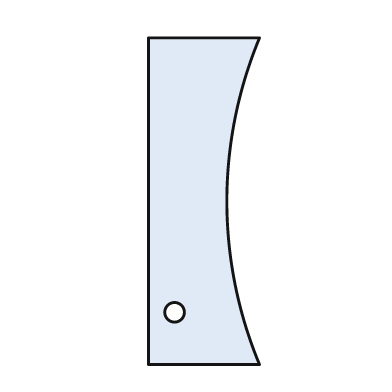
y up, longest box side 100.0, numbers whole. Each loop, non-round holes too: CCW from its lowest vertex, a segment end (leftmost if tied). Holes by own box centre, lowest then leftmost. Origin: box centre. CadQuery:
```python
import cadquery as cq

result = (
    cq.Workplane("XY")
    .moveTo(-17.0, -50.0)
    .lineTo(17.0, -50.0)
    .threePointArc((7.0, 0.0), (17.0, 50.0))
    .lineTo(-17.0, 50.0)
    .close()
    .moveTo(-9.0, -34.0)
    .circle(3.0)
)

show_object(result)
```